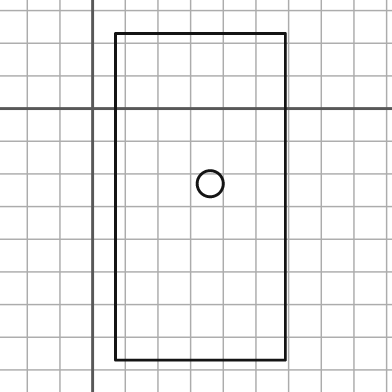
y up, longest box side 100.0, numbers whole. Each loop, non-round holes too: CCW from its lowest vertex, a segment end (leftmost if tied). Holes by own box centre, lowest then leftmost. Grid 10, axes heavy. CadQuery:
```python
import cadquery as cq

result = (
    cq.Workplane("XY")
    .moveTo(7.0, -77.0)
    .lineTo(59.0, -77.0)
    .lineTo(59.0, 23.0)
    .lineTo(7.0, 23.0)
    .close()
    .moveTo(36.0, -23.0)
    .circle(4.0)
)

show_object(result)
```